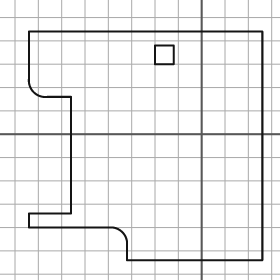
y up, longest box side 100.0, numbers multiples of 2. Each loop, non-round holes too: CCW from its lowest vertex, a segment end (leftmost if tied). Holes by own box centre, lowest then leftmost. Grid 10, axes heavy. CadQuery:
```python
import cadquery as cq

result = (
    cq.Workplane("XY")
    .moveTo(-32.0, -54.0)
    .lineTo(26.0, -54.0)
    .lineTo(26.0, 44.0)
    .lineTo(-74.0, 44.0)
    .lineTo(-74.0, 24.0)
    .threePointArc((-72.0, 18.0), (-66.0, 16.0))
    .lineTo(-56.0, 16.0)
    .lineTo(-56.0, -34.0)
    .lineTo(-74.0, -34.0)
    .lineTo(-74.0, -40.0)
    .lineTo(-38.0, -40.0)
    .threePointArc((-34.0, -42.0), (-32.0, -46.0))
    .close()
    .moveTo(-20.0, 30.0)
    .lineTo(-12.0, 30.0)
    .lineTo(-12.0, 38.0)
    .lineTo(-20.0, 38.0)
    .close()
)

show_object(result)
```